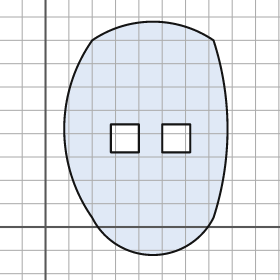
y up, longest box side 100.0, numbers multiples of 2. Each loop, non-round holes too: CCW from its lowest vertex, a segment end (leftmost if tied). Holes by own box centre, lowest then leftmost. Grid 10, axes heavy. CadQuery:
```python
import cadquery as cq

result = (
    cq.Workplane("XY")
    .moveTo(20.0, 4.0)
    .threePointArc((46.0, -12.0), (72.0, 4.0))
    .threePointArc((78.0, 42.0), (72.0, 80.0))
    .threePointArc((46.0, 88.0), (20.0, 80.0))
    .threePointArc((8.0, 42.0), (20.0, 4.0))
    .close()
    .moveTo(28.0, 32.0)
    .lineTo(40.0, 32.0)
    .lineTo(40.0, 44.0)
    .lineTo(28.0, 44.0)
    .close()
    .moveTo(50.0, 32.0)
    .lineTo(62.0, 32.0)
    .lineTo(62.0, 44.0)
    .lineTo(50.0, 44.0)
    .close()
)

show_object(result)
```